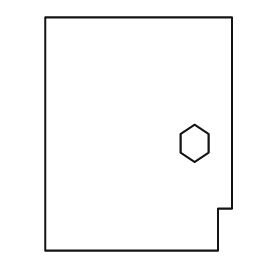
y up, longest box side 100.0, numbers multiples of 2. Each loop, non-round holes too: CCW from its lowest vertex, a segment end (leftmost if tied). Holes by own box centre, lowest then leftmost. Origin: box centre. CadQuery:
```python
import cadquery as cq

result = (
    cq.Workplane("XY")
    .moveTo(-40.0, -50.0)
    .lineTo(34.0, -50.0)
    .lineTo(34.0, -32.0)
    .lineTo(40.0, -32.0)
    .lineTo(40.0, 50.0)
    .lineTo(-40.0, 50.0)
    .close()
    .moveTo(24.0, -12.0)
    .lineTo(30.0, -8.0)
    .lineTo(30.0, 0.0)
    .lineTo(24.0, 4.0)
    .lineTo(18.0, 0.0)
    .lineTo(18.0, -8.0)
    .close()
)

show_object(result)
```